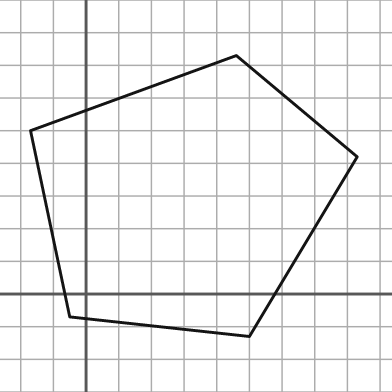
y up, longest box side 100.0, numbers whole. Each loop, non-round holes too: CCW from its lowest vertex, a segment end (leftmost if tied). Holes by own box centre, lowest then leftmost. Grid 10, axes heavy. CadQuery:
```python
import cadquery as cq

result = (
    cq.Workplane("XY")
    .moveTo(50.0, -13.0)
    .lineTo(83.0, 42.0)
    .lineTo(46.0, 73.0)
    .lineTo(-17.0, 50.0)
    .lineTo(-5.0, -7.0)
    .close()
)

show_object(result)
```